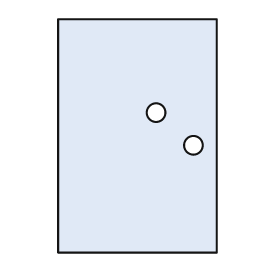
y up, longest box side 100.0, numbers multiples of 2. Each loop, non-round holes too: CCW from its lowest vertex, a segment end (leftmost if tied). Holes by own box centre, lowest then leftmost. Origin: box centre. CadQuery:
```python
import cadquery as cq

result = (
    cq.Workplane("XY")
    .moveTo(-34.0, -50.0)
    .lineTo(34.0, -50.0)
    .lineTo(34.0, 50.0)
    .lineTo(-34.0, 50.0)
    .close()
    .moveTo(24.0, -4.0)
    .circle(4.0)
    .moveTo(8.0, 10.0)
    .circle(4.0)
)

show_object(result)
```